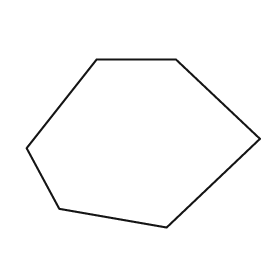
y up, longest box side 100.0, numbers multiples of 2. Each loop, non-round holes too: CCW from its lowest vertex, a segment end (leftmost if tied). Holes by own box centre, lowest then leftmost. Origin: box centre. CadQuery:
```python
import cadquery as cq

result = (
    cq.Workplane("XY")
    .moveTo(10.0, -36.0)
    .lineTo(50.0, 2.0)
    .lineTo(14.0, 36.0)
    .lineTo(-20.0, 36.0)
    .lineTo(-50.0, -2.0)
    .lineTo(-36.0, -28.0)
    .close()
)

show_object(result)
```